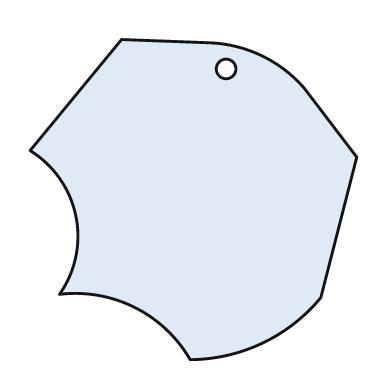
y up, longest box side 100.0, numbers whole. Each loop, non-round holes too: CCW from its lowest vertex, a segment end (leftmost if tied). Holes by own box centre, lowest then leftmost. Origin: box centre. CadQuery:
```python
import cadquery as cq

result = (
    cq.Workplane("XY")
    .moveTo(-1.0, -49.0)
    .threePointArc((21.0, -44.0), (39.0, -30.0))
    .lineTo(50.0, 13.0)
    .lineTo(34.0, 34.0)
    .threePointArc((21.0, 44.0), (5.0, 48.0))
    .lineTo(-22.0, 49.0)
    .lineTo(-50.0, 15.0)
    .threePointArc((-36.0, -5.0), (-41.0, -29.0))
    .threePointArc((-18.0, -33.0), (-1.0, -49.0))
    .close()
    .moveTo(10.0, 40.0)
    .circle(3.0)
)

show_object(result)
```